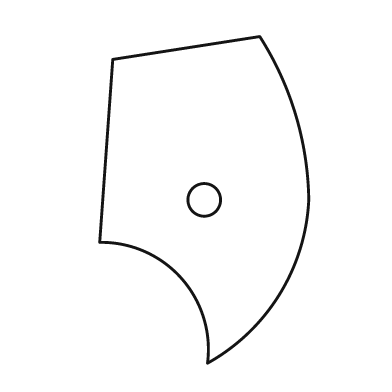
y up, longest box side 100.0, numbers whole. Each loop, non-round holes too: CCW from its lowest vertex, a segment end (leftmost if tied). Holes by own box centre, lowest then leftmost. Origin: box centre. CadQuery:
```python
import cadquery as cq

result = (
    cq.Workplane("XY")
    .moveTo(1.0, -50.0)
    .threePointArc((23.0, -29.0), (32.0, 0.0))
    .threePointArc((28.0, 26.0), (17.0, 50.0))
    .lineTo(-28.0, 43.0)
    .lineTo(-32.0, -13.0)
    .threePointArc((-7.0, -24.0), (1.0, -50.0))
    .close()
    .moveTo(0.0, 0.0)
    .circle(5.0)
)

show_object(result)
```